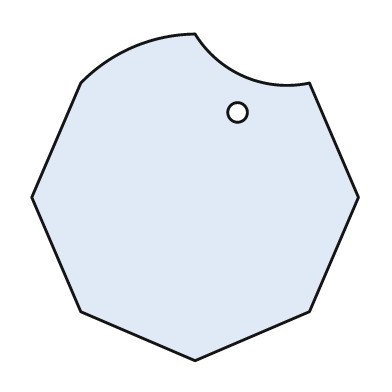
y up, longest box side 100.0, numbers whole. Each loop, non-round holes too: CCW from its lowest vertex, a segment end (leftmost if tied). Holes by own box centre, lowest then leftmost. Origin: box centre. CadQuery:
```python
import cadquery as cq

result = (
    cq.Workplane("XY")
    .moveTo(0.0, -50.0)
    .lineTo(35.0, -35.0)
    .lineTo(50.0, 0.0)
    .lineTo(35.0, 35.0)
    .threePointArc((15.0, 37.0), (0.0, 50.0))
    .threePointArc((-19.0, 46.0), (-35.0, 35.0))
    .lineTo(-50.0, 0.0)
    .lineTo(-35.0, -35.0)
    .close()
    .moveTo(13.0, 26.0)
    .circle(3.0)
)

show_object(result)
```